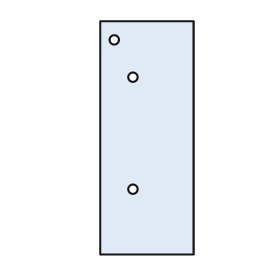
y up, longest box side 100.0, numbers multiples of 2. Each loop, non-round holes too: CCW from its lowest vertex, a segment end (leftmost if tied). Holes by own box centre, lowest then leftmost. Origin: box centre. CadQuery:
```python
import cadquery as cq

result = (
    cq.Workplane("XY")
    .moveTo(-20.0, -50.0)
    .lineTo(20.0, -50.0)
    .lineTo(20.0, 50.0)
    .lineTo(-20.0, 50.0)
    .close()
    .moveTo(-6.0, -22.0)
    .circle(2.0)
    .moveTo(-6.0, 26.0)
    .circle(2.0)
    .moveTo(-14.0, 42.0)
    .circle(2.0)
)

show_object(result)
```